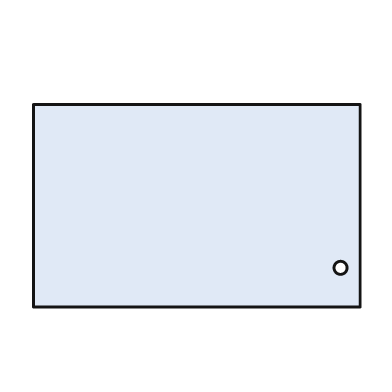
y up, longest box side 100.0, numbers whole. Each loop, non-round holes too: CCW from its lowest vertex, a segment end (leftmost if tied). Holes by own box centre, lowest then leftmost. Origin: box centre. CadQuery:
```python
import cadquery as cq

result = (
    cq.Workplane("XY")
    .moveTo(-50.0, -31.0)
    .lineTo(50.0, -31.0)
    .lineTo(50.0, 31.0)
    .lineTo(-50.0, 31.0)
    .close()
    .moveTo(44.0, -19.0)
    .circle(2.0)
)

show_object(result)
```